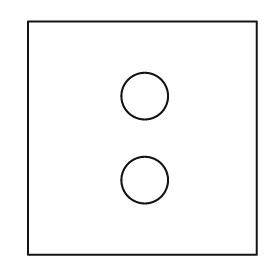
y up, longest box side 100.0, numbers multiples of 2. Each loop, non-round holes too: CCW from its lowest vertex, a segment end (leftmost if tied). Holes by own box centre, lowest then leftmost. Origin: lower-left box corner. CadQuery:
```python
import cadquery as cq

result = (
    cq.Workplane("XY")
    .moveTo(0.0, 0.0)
    .lineTo(98.0, 0.0)
    .lineTo(98.0, 100.0)
    .lineTo(0.0, 100.0)
    .close()
    .moveTo(50.0, 32.0)
    .circle(10.0)
    .moveTo(50.0, 68.0)
    .circle(10.0)
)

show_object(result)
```